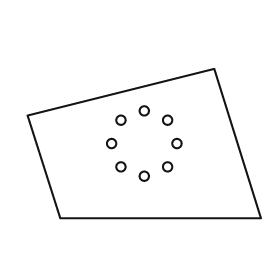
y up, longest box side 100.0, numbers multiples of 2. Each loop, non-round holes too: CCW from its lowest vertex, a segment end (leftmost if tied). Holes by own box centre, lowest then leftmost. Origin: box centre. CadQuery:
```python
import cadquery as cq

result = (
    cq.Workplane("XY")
    .moveTo(-36.0, -32.0)
    .lineTo(50.0, -32.0)
    .lineTo(30.0, 32.0)
    .lineTo(-50.0, 12.0)
    .close()
    .moveTo(0.0, -14.0)
    .circle(2.0)
    .moveTo(-10.0, -10.0)
    .circle(2.0)
    .moveTo(10.0, -10.0)
    .circle(2.0)
    .moveTo(-14.0, 0.0)
    .circle(2.0)
    .moveTo(14.0, 0.0)
    .circle(2.0)
    .moveTo(-10.0, 10.0)
    .circle(2.0)
    .moveTo(10.0, 10.0)
    .circle(2.0)
    .moveTo(0.0, 14.0)
    .circle(2.0)
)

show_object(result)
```